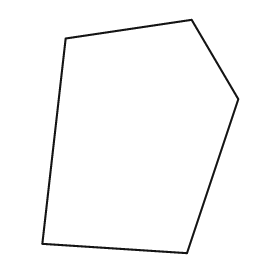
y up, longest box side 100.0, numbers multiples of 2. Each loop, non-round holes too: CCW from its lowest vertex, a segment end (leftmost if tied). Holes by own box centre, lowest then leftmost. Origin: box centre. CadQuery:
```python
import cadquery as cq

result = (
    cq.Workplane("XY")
    .moveTo(20.0, -50.0)
    .lineTo(42.0, 16.0)
    .lineTo(22.0, 50.0)
    .lineTo(-32.0, 42.0)
    .lineTo(-42.0, -46.0)
    .close()
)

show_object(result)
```